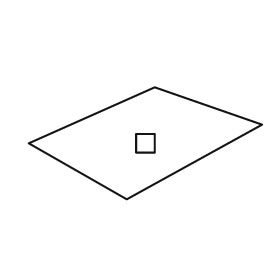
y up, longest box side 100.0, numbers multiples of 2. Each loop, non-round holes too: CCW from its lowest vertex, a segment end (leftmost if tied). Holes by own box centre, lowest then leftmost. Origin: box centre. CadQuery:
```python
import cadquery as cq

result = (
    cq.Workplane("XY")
    .moveTo(-8.0, -24.0)
    .lineTo(50.0, 8.0)
    .lineTo(4.0, 24.0)
    .lineTo(-50.0, 0.0)
    .close()
    .moveTo(-4.0, -4.0)
    .lineTo(4.0, -4.0)
    .lineTo(4.0, 4.0)
    .lineTo(-4.0, 4.0)
    .close()
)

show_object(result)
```